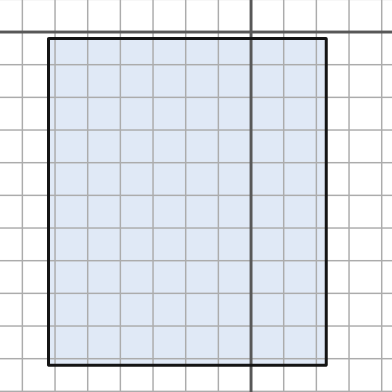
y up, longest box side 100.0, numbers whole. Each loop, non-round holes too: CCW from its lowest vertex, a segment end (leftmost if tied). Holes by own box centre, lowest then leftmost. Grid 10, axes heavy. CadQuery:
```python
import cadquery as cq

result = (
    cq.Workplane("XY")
    .moveTo(-62.0, -102.0)
    .lineTo(23.0, -102.0)
    .lineTo(23.0, -2.0)
    .lineTo(-62.0, -2.0)
    .close()
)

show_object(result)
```